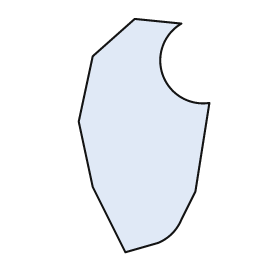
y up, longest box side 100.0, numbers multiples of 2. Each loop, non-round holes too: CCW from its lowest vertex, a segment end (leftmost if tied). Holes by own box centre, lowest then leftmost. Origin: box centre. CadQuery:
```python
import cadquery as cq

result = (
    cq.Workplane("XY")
    .moveTo(-8.0, -50.0)
    .lineTo(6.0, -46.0)
    .threePointArc((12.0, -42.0), (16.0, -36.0))
    .lineTo(22.0, -24.0)
    .lineTo(28.0, 14.0)
    .threePointArc((8.0, 26.0), (16.0, 48.0))
    .lineTo(-4.0, 50.0)
    .lineTo(-22.0, 34.0)
    .lineTo(-28.0, 6.0)
    .lineTo(-22.0, -22.0)
    .close()
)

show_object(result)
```